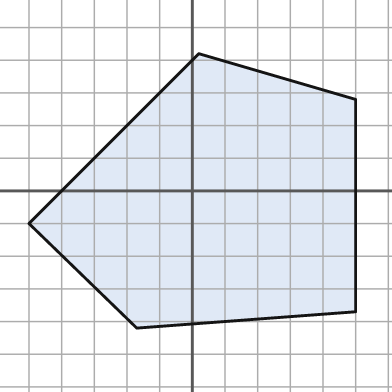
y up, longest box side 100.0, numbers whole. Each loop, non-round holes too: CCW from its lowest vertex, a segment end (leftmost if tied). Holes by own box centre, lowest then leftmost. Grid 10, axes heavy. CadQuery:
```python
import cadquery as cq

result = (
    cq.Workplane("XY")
    .moveTo(-17.0, -42.0)
    .lineTo(50.0, -37.0)
    .lineTo(50.0, 28.0)
    .lineTo(2.0, 42.0)
    .lineTo(-50.0, -10.0)
    .close()
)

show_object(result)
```